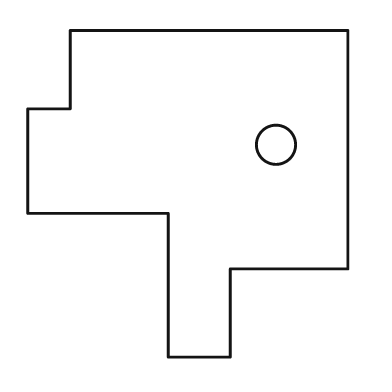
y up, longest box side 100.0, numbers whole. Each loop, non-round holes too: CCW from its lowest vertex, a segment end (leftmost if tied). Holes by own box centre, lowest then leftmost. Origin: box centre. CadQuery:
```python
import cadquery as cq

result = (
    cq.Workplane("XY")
    .moveTo(-6.0, -50.0)
    .lineTo(13.0, -50.0)
    .lineTo(13.0, -23.0)
    .lineTo(49.0, -23.0)
    .lineTo(49.0, 50.0)
    .lineTo(-36.0, 50.0)
    .lineTo(-36.0, 26.0)
    .lineTo(-49.0, 26.0)
    .lineTo(-49.0, -6.0)
    .lineTo(-6.0, -6.0)
    .close()
    .moveTo(27.0, 15.0)
    .circle(6.0)
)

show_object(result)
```